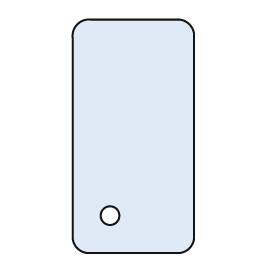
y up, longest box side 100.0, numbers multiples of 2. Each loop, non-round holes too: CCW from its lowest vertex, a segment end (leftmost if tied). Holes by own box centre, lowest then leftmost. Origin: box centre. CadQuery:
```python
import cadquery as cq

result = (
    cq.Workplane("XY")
    .moveTo(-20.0, -50.0)
    .lineTo(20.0, -50.0)
    .threePointArc((24.0, -48.0), (26.0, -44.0))
    .lineTo(26.0, 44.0)
    .threePointArc((24.0, 48.0), (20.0, 50.0))
    .lineTo(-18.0, 50.0)
    .threePointArc((-24.0, 48.0), (-26.0, 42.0))
    .lineTo(-26.0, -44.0)
    .threePointArc((-24.0, -48.0), (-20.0, -50.0))
    .close()
    .moveTo(-10.0, -34.0)
    .circle(4.0)
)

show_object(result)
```